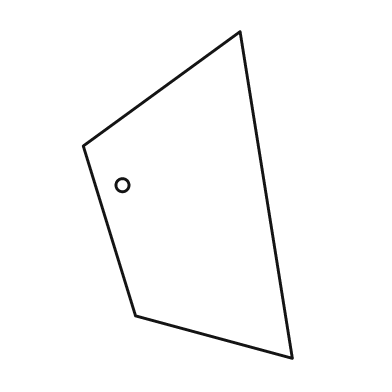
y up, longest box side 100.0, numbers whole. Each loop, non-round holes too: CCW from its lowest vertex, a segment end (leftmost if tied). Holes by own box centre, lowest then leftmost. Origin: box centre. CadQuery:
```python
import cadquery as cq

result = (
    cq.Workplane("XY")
    .moveTo(32.0, -50.0)
    .lineTo(16.0, 50.0)
    .lineTo(-32.0, 15.0)
    .lineTo(-16.0, -37.0)
    .close()
    .moveTo(-20.0, 3.0)
    .circle(2.0)
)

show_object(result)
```